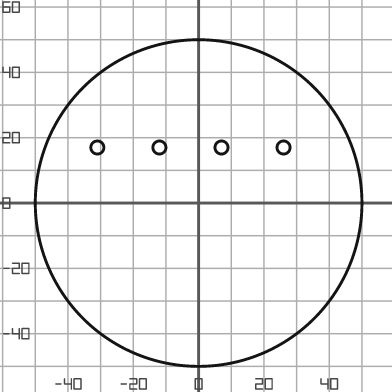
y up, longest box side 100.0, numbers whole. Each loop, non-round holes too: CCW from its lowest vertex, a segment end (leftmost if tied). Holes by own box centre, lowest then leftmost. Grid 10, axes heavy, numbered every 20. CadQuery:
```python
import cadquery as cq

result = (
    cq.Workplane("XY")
    .moveTo(0.0, 0.0)
    .circle(50.0)
    .moveTo(-31.0, 17.0)
    .circle(2.0)
    .moveTo(-12.0, 17.0)
    .circle(2.0)
    .moveTo(7.0, 17.0)
    .circle(2.0)
    .moveTo(26.0, 17.0)
    .circle(2.0)
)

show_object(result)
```